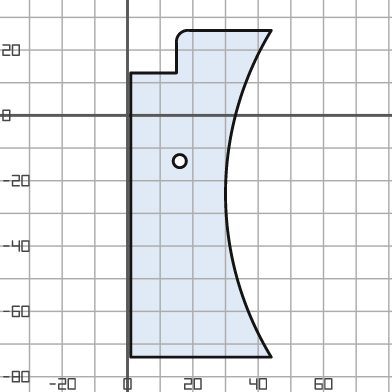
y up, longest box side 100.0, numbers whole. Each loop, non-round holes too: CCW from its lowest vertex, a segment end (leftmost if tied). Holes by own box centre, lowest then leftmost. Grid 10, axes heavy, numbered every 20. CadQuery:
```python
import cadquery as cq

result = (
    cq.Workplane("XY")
    .moveTo(1.0, -74.0)
    .lineTo(44.0, -74.0)
    .threePointArc((30.0, -24.0), (44.0, 26.0))
    .lineTo(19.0, 26.0)
    .threePointArc((16.0, 25.0), (15.0, 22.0))
    .lineTo(15.0, 13.0)
    .lineTo(1.0, 13.0)
    .close()
    .moveTo(16.0, -14.0)
    .circle(2.0)
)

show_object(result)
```